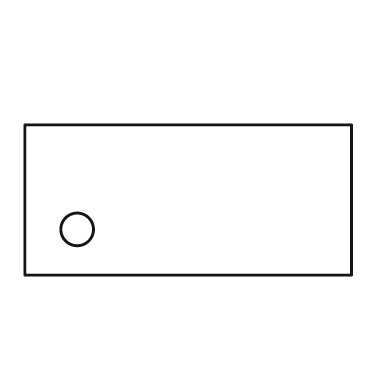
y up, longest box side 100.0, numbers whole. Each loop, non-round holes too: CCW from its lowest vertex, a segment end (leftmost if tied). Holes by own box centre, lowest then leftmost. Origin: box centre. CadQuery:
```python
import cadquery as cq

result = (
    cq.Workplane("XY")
    .moveTo(-50.0, -23.0)
    .lineTo(50.0, -23.0)
    .lineTo(50.0, 23.0)
    .lineTo(-50.0, 23.0)
    .close()
    .moveTo(-34.0, -9.0)
    .circle(5.0)
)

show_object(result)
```